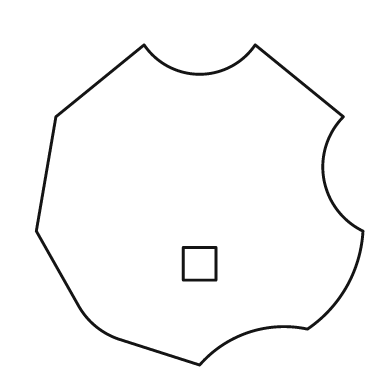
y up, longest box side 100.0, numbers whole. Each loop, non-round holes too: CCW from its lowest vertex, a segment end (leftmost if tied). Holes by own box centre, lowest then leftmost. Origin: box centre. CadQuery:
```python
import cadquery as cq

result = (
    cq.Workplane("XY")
    .moveTo(0.0, -49.0)
    .threePointArc((15.0, -39.0), (33.0, -38.0))
    .threePointArc((45.0, -25.0), (50.0, -8.0))
    .threePointArc((38.0, 8.0), (44.0, 27.0))
    .lineTo(17.0, 49.0)
    .threePointArc((0.0, 40.0), (-17.0, 49.0))
    .lineTo(-44.0, 27.0)
    .lineTo(-50.0, -8.0)
    .lineTo(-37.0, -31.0)
    .threePointArc((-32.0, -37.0), (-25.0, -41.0))
    .close()
    .moveTo(-5.0, -23.0)
    .lineTo(5.0, -23.0)
    .lineTo(5.0, -13.0)
    .lineTo(-5.0, -13.0)
    .close()
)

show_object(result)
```